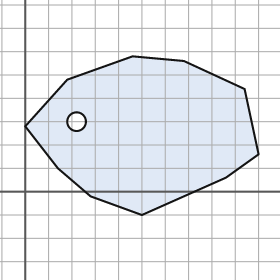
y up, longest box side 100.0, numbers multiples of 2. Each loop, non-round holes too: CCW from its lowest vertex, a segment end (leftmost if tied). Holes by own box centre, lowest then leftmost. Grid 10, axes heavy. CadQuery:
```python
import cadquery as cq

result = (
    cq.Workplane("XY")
    .moveTo(50.0, -10.0)
    .lineTo(86.0, 6.0)
    .lineTo(100.0, 16.0)
    .lineTo(94.0, 44.0)
    .lineTo(68.0, 56.0)
    .lineTo(46.0, 58.0)
    .lineTo(18.0, 48.0)
    .lineTo(0.0, 28.0)
    .lineTo(14.0, 10.0)
    .lineTo(28.0, -2.0)
    .close()
    .moveTo(22.0, 30.0)
    .circle(4.0)
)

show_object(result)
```